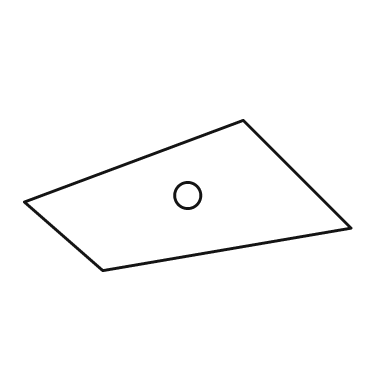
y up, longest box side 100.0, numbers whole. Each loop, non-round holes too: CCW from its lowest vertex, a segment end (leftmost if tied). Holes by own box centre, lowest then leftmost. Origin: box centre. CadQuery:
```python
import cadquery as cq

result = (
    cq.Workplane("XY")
    .moveTo(-26.0, -23.0)
    .lineTo(50.0, -10.0)
    .lineTo(17.0, 23.0)
    .lineTo(-50.0, -2.0)
    .close()
    .moveTo(0.0, 0.0)
    .circle(4.0)
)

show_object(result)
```